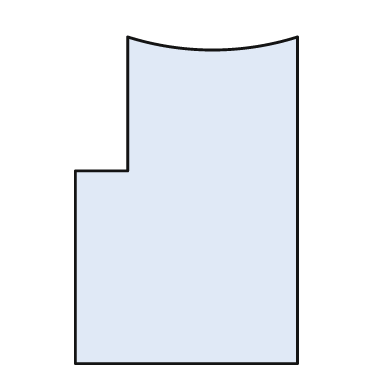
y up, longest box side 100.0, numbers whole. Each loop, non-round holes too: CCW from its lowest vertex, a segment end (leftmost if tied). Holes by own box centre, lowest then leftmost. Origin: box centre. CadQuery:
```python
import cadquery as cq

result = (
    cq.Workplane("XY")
    .moveTo(-34.0, -50.0)
    .lineTo(34.0, -50.0)
    .lineTo(34.0, 50.0)
    .threePointArc((8.0, 46.0), (-18.0, 50.0))
    .lineTo(-18.0, 9.0)
    .lineTo(-34.0, 9.0)
    .close()
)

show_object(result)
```